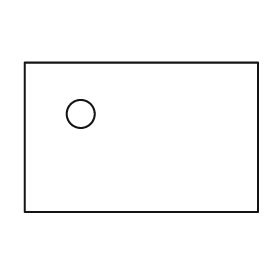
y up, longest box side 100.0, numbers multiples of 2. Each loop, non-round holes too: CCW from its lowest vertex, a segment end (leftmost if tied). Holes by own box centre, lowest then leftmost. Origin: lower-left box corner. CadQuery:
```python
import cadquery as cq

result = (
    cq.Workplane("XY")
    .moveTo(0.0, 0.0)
    .lineTo(100.0, 0.0)
    .lineTo(100.0, 64.0)
    .lineTo(0.0, 64.0)
    .close()
    .moveTo(24.0, 42.0)
    .circle(6.0)
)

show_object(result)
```